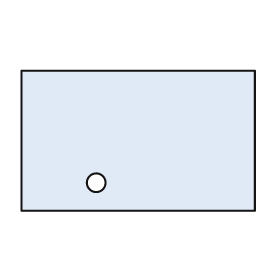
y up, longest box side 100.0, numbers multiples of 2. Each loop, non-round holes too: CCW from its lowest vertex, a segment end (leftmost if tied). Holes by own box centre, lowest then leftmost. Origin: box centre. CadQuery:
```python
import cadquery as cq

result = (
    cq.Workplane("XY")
    .moveTo(-50.0, -30.0)
    .lineTo(50.0, -30.0)
    .lineTo(50.0, 30.0)
    .lineTo(-50.0, 30.0)
    .close()
    .moveTo(-18.0, -18.0)
    .circle(4.0)
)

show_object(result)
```